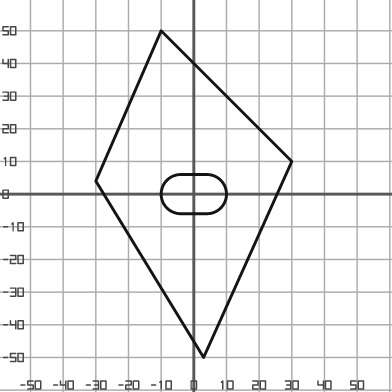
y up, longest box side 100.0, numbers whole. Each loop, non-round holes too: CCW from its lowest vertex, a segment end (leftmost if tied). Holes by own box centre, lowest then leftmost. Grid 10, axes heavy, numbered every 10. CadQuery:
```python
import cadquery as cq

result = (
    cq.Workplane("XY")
    .moveTo(3.0, -50.0)
    .lineTo(30.0, 10.0)
    .lineTo(-10.0, 50.0)
    .lineTo(-30.0, 4.0)
    .close()
    .moveTo(-4.0, -6.0)
    .lineTo(4.0, -6.0)
    .threePointArc((10.0, 0.0), (4.0, 6.0))
    .lineTo(-4.0, 6.0)
    .threePointArc((-10.0, 0.0), (-4.0, -6.0))
    .close()
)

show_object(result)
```